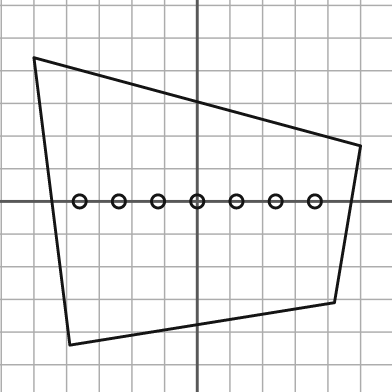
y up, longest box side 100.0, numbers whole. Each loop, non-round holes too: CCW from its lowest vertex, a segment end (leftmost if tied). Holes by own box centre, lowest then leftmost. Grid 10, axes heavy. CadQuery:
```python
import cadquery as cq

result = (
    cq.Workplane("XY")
    .moveTo(-39.0, -44.0)
    .lineTo(42.0, -31.0)
    .lineTo(50.0, 17.0)
    .lineTo(-50.0, 44.0)
    .close()
    .moveTo(-36.0, 0.0)
    .circle(2.0)
    .moveTo(-24.0, 0.0)
    .circle(2.0)
    .moveTo(-12.0, 0.0)
    .circle(2.0)
    .moveTo(0.0, 0.0)
    .circle(2.0)
    .moveTo(12.0, 0.0)
    .circle(2.0)
    .moveTo(24.0, 0.0)
    .circle(2.0)
    .moveTo(36.0, 0.0)
    .circle(2.0)
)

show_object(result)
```